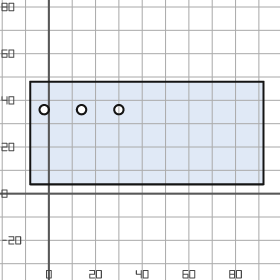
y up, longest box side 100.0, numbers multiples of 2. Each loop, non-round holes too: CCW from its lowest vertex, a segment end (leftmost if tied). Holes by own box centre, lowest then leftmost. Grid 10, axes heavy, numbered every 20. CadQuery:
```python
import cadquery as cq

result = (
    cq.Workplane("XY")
    .moveTo(-8.0, 4.0)
    .lineTo(92.0, 4.0)
    .lineTo(92.0, 48.0)
    .lineTo(-8.0, 48.0)
    .close()
    .moveTo(-2.0, 36.0)
    .circle(2.0)
    .moveTo(14.0, 36.0)
    .circle(2.0)
    .moveTo(30.0, 36.0)
    .circle(2.0)
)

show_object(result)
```